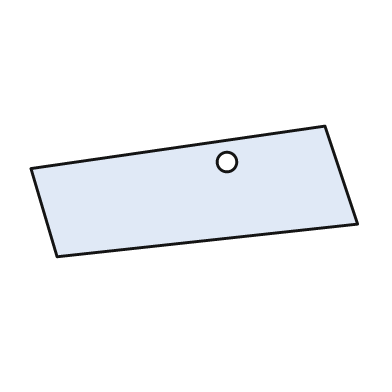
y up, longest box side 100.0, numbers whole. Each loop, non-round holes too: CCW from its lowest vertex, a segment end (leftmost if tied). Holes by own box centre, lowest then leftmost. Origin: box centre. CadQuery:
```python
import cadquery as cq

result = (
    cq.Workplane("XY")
    .moveTo(-42.0, -20.0)
    .lineTo(50.0, -10.0)
    .lineTo(40.0, 20.0)
    .lineTo(-50.0, 7.0)
    .close()
    .moveTo(10.0, 9.0)
    .circle(3.0)
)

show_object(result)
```